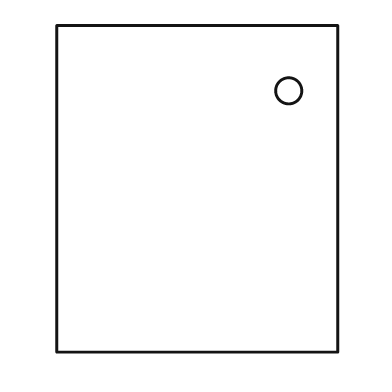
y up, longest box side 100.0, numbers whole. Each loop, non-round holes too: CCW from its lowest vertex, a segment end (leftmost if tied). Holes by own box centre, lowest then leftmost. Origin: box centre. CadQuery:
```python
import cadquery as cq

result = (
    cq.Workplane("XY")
    .moveTo(-43.0, -50.0)
    .lineTo(43.0, -50.0)
    .lineTo(43.0, 50.0)
    .lineTo(-43.0, 50.0)
    .close()
    .moveTo(28.0, 30.0)
    .circle(4.0)
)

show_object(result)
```